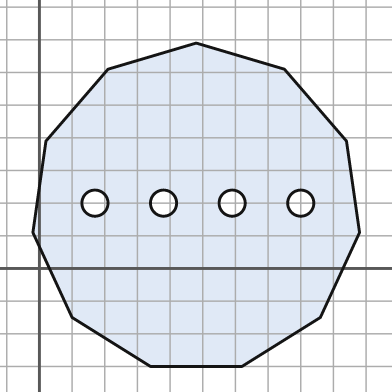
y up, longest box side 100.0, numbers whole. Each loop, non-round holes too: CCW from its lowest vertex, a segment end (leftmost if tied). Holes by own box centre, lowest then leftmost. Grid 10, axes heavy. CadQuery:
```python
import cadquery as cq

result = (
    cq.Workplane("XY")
    .moveTo(34.0, -30.0)
    .lineTo(62.0, -30.0)
    .lineTo(86.0, -15.0)
    .lineTo(98.0, 11.0)
    .lineTo(94.0, 39.0)
    .lineTo(75.0, 61.0)
    .lineTo(48.0, 69.0)
    .lineTo(21.0, 61.0)
    .lineTo(2.0, 39.0)
    .lineTo(-2.0, 11.0)
    .lineTo(10.0, -15.0)
    .close()
    .moveTo(17.0, 20.0)
    .circle(4.0)
    .moveTo(38.0, 20.0)
    .circle(4.0)
    .moveTo(59.0, 20.0)
    .circle(4.0)
    .moveTo(80.0, 20.0)
    .circle(4.0)
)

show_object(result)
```